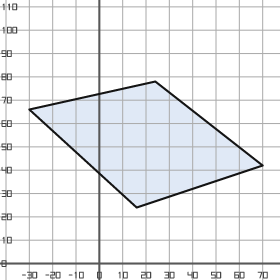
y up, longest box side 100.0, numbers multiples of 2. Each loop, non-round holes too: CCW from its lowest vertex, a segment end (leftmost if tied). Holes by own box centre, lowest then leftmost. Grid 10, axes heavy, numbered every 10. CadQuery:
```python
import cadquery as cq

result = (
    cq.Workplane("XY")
    .moveTo(16.0, 24.0)
    .lineTo(70.0, 42.0)
    .lineTo(24.0, 78.0)
    .lineTo(-30.0, 66.0)
    .close()
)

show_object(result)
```